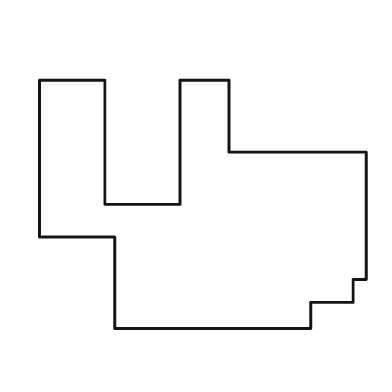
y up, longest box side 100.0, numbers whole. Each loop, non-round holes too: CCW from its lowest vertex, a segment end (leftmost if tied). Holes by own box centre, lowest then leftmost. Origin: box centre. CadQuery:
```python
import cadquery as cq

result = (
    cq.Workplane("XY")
    .moveTo(-27.0, -38.0)
    .lineTo(33.0, -38.0)
    .lineTo(33.0, -30.0)
    .lineTo(46.0, -30.0)
    .lineTo(46.0, -23.0)
    .lineTo(50.0, -23.0)
    .lineTo(50.0, 16.0)
    .lineTo(8.0, 16.0)
    .lineTo(8.0, 38.0)
    .lineTo(-7.0, 38.0)
    .lineTo(-7.0, 0.0)
    .lineTo(-30.0, 0.0)
    .lineTo(-30.0, 38.0)
    .lineTo(-50.0, 38.0)
    .lineTo(-50.0, -10.0)
    .lineTo(-27.0, -10.0)
    .close()
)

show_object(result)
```